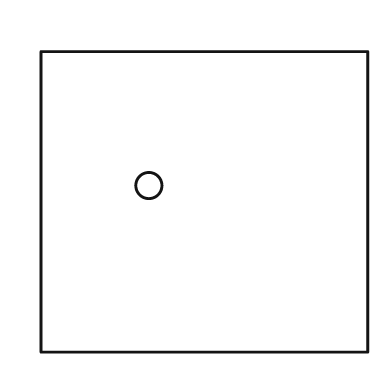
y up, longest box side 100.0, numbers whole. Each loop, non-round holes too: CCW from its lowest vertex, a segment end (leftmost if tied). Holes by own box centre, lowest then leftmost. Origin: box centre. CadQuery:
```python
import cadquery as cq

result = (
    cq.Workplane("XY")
    .moveTo(-50.0, -46.0)
    .lineTo(50.0, -46.0)
    .lineTo(50.0, 46.0)
    .lineTo(-50.0, 46.0)
    .close()
    .moveTo(-17.0, 5.0)
    .circle(4.0)
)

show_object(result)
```